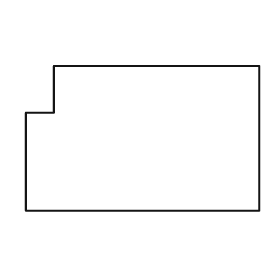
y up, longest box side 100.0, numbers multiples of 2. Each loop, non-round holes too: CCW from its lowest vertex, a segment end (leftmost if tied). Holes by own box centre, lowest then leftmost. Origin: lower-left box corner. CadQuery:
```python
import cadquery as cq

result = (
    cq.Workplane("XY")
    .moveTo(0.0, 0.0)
    .lineTo(100.0, 0.0)
    .lineTo(100.0, 62.0)
    .lineTo(12.0, 62.0)
    .lineTo(12.0, 42.0)
    .lineTo(0.0, 42.0)
    .close()
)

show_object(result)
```